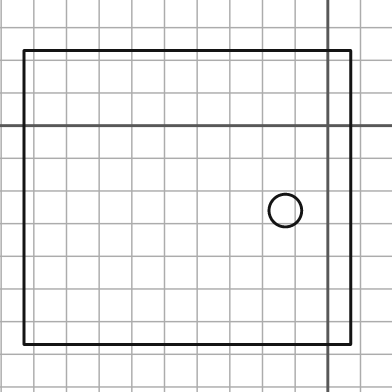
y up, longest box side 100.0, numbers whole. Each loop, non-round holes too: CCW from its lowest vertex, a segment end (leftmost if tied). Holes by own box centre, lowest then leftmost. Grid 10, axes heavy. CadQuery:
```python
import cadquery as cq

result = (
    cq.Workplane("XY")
    .moveTo(-93.0, -67.0)
    .lineTo(7.0, -67.0)
    .lineTo(7.0, 23.0)
    .lineTo(-93.0, 23.0)
    .close()
    .moveTo(-13.0, -26.0)
    .circle(5.0)
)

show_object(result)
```